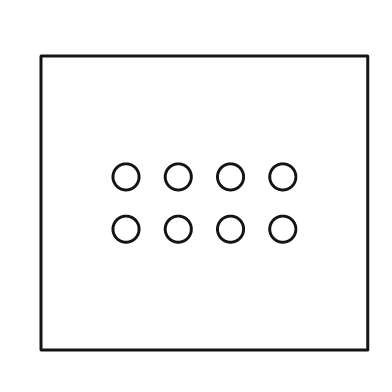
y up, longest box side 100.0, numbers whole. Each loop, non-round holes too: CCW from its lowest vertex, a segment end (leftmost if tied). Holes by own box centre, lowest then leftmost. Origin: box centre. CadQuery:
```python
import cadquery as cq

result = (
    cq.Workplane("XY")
    .moveTo(-50.0, -45.0)
    .lineTo(50.0, -45.0)
    .lineTo(50.0, 45.0)
    .lineTo(-50.0, 45.0)
    .close()
    .moveTo(-24.0, -8.0)
    .circle(4.0)
    .moveTo(-8.0, -8.0)
    .circle(4.0)
    .moveTo(8.0, -8.0)
    .circle(4.0)
    .moveTo(24.0, -8.0)
    .circle(4.0)
    .moveTo(-24.0, 8.0)
    .circle(4.0)
    .moveTo(-8.0, 8.0)
    .circle(4.0)
    .moveTo(8.0, 8.0)
    .circle(4.0)
    .moveTo(24.0, 8.0)
    .circle(4.0)
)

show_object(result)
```